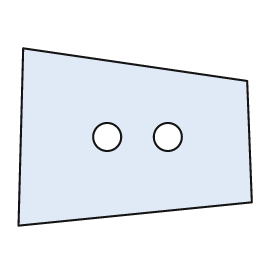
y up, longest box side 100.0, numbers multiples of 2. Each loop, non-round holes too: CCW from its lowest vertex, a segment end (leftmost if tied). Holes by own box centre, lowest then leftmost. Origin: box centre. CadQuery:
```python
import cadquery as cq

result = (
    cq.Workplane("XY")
    .moveTo(-50.0, -38.0)
    .lineTo(50.0, -28.0)
    .lineTo(48.0, 24.0)
    .lineTo(-48.0, 38.0)
    .close()
    .moveTo(-12.0, 0.0)
    .circle(6.0)
    .moveTo(14.0, 0.0)
    .circle(6.0)
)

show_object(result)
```